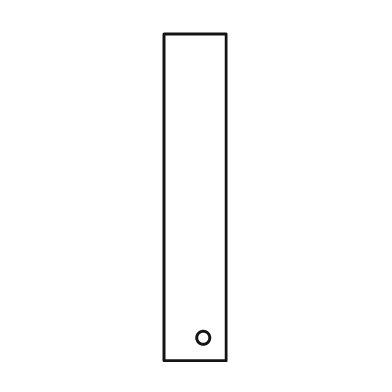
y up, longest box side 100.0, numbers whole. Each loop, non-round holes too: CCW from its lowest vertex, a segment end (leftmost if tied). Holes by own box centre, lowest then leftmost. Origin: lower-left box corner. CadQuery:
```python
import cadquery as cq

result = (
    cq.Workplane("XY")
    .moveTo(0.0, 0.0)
    .lineTo(19.0, 0.0)
    .lineTo(19.0, 100.0)
    .lineTo(0.0, 100.0)
    .close()
    .moveTo(12.0, 7.0)
    .circle(2.0)
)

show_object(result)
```